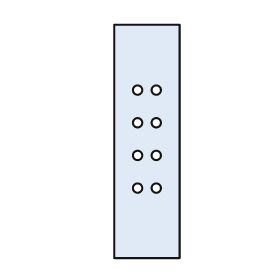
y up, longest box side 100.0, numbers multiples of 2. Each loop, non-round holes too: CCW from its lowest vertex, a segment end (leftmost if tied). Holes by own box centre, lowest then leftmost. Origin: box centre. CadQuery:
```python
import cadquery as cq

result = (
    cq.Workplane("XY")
    .moveTo(-14.0, -50.0)
    .lineTo(14.0, -50.0)
    .lineTo(14.0, 50.0)
    .lineTo(-14.0, 50.0)
    .close()
    .moveTo(-4.0, -20.0)
    .circle(2.0)
    .moveTo(4.0, -20.0)
    .circle(2.0)
    .moveTo(-4.0, -6.0)
    .circle(2.0)
    .moveTo(4.0, -6.0)
    .circle(2.0)
    .moveTo(-4.0, 8.0)
    .circle(2.0)
    .moveTo(4.0, 8.0)
    .circle(2.0)
    .moveTo(-4.0, 22.0)
    .circle(2.0)
    .moveTo(4.0, 22.0)
    .circle(2.0)
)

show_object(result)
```